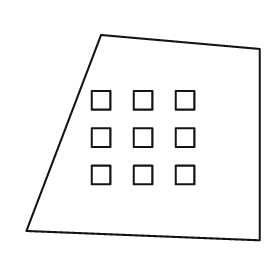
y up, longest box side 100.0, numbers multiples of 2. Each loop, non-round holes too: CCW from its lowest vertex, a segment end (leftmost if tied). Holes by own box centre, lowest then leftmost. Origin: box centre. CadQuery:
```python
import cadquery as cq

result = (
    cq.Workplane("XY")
    .moveTo(50.0, -44.0)
    .lineTo(50.0, 38.0)
    .lineTo(-18.0, 44.0)
    .lineTo(-50.0, -40.0)
    .close()
    .moveTo(-22.0, -20.0)
    .lineTo(-14.0, -20.0)
    .lineTo(-14.0, -12.0)
    .lineTo(-22.0, -12.0)
    .close()
    .moveTo(-4.0, -20.0)
    .lineTo(4.0, -20.0)
    .lineTo(4.0, -12.0)
    .lineTo(-4.0, -12.0)
    .close()
    .moveTo(14.0, -20.0)
    .lineTo(22.0, -20.0)
    .lineTo(22.0, -12.0)
    .lineTo(14.0, -12.0)
    .close()
    .moveTo(-22.0, -4.0)
    .lineTo(-14.0, -4.0)
    .lineTo(-14.0, 4.0)
    .lineTo(-22.0, 4.0)
    .close()
    .moveTo(-4.0, -4.0)
    .lineTo(4.0, -4.0)
    .lineTo(4.0, 4.0)
    .lineTo(-4.0, 4.0)
    .close()
    .moveTo(14.0, -4.0)
    .lineTo(22.0, -4.0)
    .lineTo(22.0, 4.0)
    .lineTo(14.0, 4.0)
    .close()
    .moveTo(-22.0, 12.0)
    .lineTo(-14.0, 12.0)
    .lineTo(-14.0, 20.0)
    .lineTo(-22.0, 20.0)
    .close()
    .moveTo(-4.0, 12.0)
    .lineTo(4.0, 12.0)
    .lineTo(4.0, 20.0)
    .lineTo(-4.0, 20.0)
    .close()
    .moveTo(14.0, 12.0)
    .lineTo(22.0, 12.0)
    .lineTo(22.0, 20.0)
    .lineTo(14.0, 20.0)
    .close()
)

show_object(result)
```